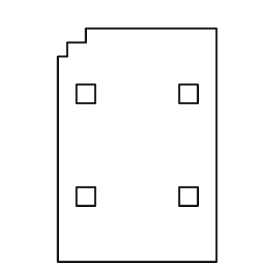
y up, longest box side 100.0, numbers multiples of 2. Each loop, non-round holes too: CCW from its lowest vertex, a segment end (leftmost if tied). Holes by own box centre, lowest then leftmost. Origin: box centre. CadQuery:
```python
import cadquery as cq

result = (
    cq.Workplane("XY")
    .moveTo(-34.0, -50.0)
    .lineTo(34.0, -50.0)
    .lineTo(34.0, 50.0)
    .lineTo(-22.0, 50.0)
    .lineTo(-22.0, 44.0)
    .lineTo(-30.0, 44.0)
    .lineTo(-30.0, 38.0)
    .lineTo(-34.0, 38.0)
    .close()
    .moveTo(-26.0, -26.0)
    .lineTo(-18.0, -26.0)
    .lineTo(-18.0, -18.0)
    .lineTo(-26.0, -18.0)
    .close()
    .moveTo(18.0, -26.0)
    .lineTo(26.0, -26.0)
    .lineTo(26.0, -18.0)
    .lineTo(18.0, -18.0)
    .close()
    .moveTo(-26.0, 18.0)
    .lineTo(-18.0, 18.0)
    .lineTo(-18.0, 26.0)
    .lineTo(-26.0, 26.0)
    .close()
    .moveTo(18.0, 18.0)
    .lineTo(26.0, 18.0)
    .lineTo(26.0, 26.0)
    .lineTo(18.0, 26.0)
    .close()
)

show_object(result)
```